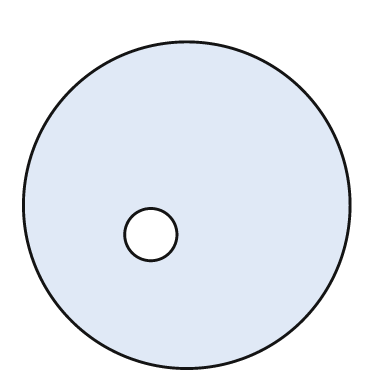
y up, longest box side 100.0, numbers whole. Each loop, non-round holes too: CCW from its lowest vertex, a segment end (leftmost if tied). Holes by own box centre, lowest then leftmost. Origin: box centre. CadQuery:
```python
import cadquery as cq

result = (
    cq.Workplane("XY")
    .moveTo(0.0, 0.0)
    .circle(50.0)
    .moveTo(-11.0, -9.0)
    .circle(8.0)
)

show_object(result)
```